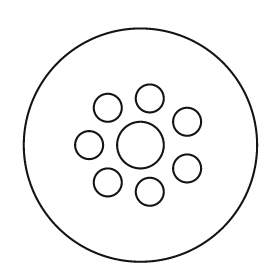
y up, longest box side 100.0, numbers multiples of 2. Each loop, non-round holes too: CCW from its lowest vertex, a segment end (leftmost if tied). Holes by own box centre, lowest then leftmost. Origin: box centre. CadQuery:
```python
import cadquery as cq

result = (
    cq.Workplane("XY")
    .moveTo(0.0, 0.0)
    .circle(50.0)
    .moveTo(4.0, -20.0)
    .circle(6.0)
    .moveTo(-14.0, -16.0)
    .circle(6.0)
    .moveTo(20.0, -10.0)
    .circle(6.0)
    .moveTo(-22.0, 0.0)
    .circle(6.0)
    .moveTo(0.0, 0.0)
    .circle(10.0)
    .moveTo(20.0, 10.0)
    .circle(6.0)
    .moveTo(-14.0, 16.0)
    .circle(6.0)
    .moveTo(4.0, 20.0)
    .circle(6.0)
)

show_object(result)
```